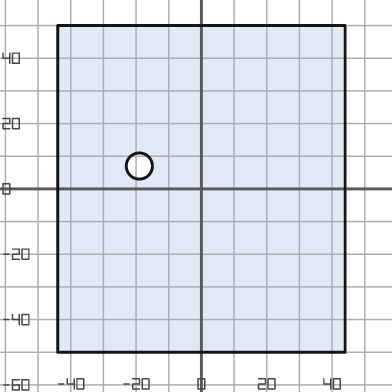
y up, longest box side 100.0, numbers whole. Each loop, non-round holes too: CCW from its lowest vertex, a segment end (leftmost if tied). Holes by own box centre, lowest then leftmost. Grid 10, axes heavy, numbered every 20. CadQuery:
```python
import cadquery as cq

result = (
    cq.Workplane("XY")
    .moveTo(-44.0, -50.0)
    .lineTo(44.0, -50.0)
    .lineTo(44.0, 50.0)
    .lineTo(-44.0, 50.0)
    .close()
    .moveTo(-19.0, 7.0)
    .circle(4.0)
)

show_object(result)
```